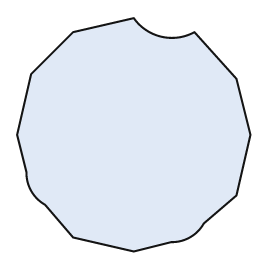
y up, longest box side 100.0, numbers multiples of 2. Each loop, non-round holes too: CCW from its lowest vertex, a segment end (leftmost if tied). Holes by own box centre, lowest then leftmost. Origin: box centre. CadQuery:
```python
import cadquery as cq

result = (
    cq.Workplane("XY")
    .moveTo(0.0, -50.0)
    .lineTo(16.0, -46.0)
    .threePointArc((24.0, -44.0), (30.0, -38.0))
    .lineTo(44.0, -26.0)
    .lineTo(50.0, 0.0)
    .lineTo(44.0, 24.0)
    .lineTo(26.0, 44.0)
    .threePointArc((12.0, 42.0), (0.0, 50.0))
    .lineTo(-26.0, 44.0)
    .lineTo(-44.0, 26.0)
    .lineTo(-50.0, 0.0)
    .lineTo(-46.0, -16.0)
    .threePointArc((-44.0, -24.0), (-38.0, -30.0))
    .lineTo(-26.0, -44.0)
    .close()
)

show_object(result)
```